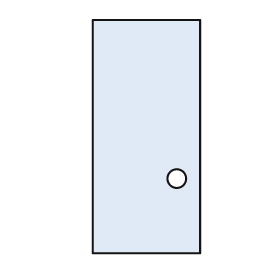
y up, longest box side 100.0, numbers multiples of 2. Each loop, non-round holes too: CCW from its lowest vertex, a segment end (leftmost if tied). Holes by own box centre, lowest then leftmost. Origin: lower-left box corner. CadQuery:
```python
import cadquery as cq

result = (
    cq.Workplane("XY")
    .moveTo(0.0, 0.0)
    .lineTo(46.0, 0.0)
    .lineTo(46.0, 100.0)
    .lineTo(0.0, 100.0)
    .close()
    .moveTo(36.0, 32.0)
    .circle(4.0)
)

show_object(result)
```